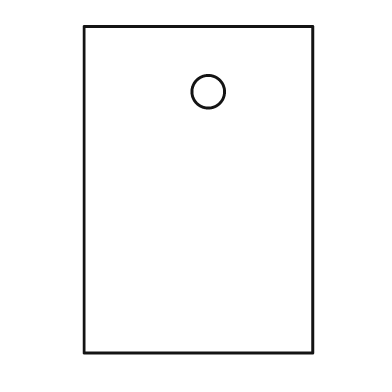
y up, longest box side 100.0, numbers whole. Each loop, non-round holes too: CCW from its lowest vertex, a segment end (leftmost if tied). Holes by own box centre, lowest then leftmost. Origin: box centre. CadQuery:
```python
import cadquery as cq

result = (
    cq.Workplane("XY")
    .moveTo(-35.0, -50.0)
    .lineTo(35.0, -50.0)
    .lineTo(35.0, 50.0)
    .lineTo(-35.0, 50.0)
    .close()
    .moveTo(3.0, 30.0)
    .circle(5.0)
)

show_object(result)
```